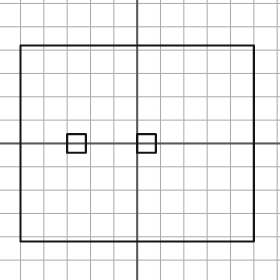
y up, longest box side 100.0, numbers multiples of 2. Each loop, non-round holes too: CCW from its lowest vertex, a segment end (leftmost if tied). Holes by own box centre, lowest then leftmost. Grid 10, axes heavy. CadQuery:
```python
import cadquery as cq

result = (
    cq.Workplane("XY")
    .moveTo(-50.0, -42.0)
    .lineTo(50.0, -42.0)
    .lineTo(50.0, 42.0)
    .lineTo(-50.0, 42.0)
    .close()
    .moveTo(-30.0, -4.0)
    .lineTo(-22.0, -4.0)
    .lineTo(-22.0, 4.0)
    .lineTo(-30.0, 4.0)
    .close()
    .moveTo(0.0, -4.0)
    .lineTo(8.0, -4.0)
    .lineTo(8.0, 4.0)
    .lineTo(0.0, 4.0)
    .close()
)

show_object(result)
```